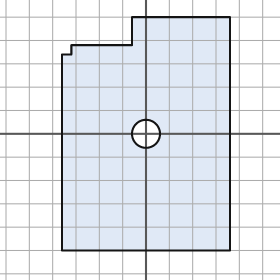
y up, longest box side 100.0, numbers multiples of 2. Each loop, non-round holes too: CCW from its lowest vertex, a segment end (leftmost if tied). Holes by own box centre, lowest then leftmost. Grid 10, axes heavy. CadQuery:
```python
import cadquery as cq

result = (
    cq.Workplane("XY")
    .moveTo(-36.0, -50.0)
    .lineTo(36.0, -50.0)
    .lineTo(36.0, 50.0)
    .lineTo(-6.0, 50.0)
    .lineTo(-6.0, 38.0)
    .lineTo(-32.0, 38.0)
    .lineTo(-32.0, 34.0)
    .lineTo(-36.0, 34.0)
    .close()
    .moveTo(0.0, 0.0)
    .circle(6.0)
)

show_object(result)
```